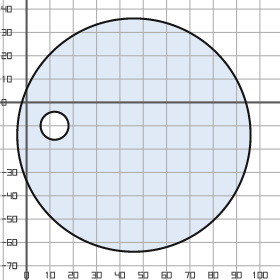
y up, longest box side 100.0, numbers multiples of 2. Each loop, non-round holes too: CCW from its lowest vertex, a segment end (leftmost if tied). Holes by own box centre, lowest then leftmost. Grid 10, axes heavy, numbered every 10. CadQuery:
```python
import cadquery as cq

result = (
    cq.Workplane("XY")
    .moveTo(46.0, -14.0)
    .circle(50.0)
    .moveTo(12.0, -10.0)
    .circle(6.0)
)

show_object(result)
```